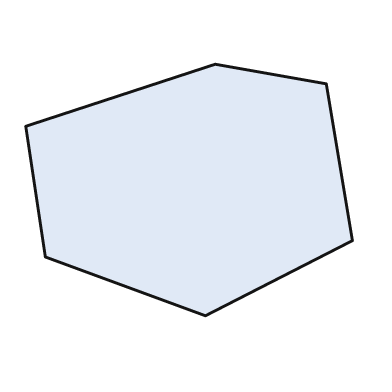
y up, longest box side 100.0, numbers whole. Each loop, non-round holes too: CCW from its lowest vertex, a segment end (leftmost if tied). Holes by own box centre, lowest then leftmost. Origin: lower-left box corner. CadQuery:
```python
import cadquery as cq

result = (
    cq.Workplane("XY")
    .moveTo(55.0, 0.0)
    .lineTo(100.0, 23.0)
    .lineTo(92.0, 71.0)
    .lineTo(58.0, 77.0)
    .lineTo(0.0, 58.0)
    .lineTo(6.0, 18.0)
    .close()
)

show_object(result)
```